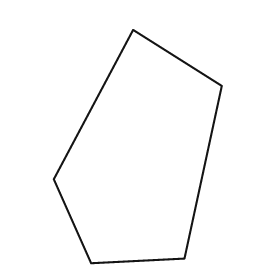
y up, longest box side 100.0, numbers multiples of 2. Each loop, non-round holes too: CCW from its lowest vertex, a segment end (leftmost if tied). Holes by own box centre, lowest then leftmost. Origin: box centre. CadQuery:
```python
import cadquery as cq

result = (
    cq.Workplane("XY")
    .moveTo(-20.0, -50.0)
    .lineTo(20.0, -48.0)
    .lineTo(36.0, 26.0)
    .lineTo(-2.0, 50.0)
    .lineTo(-36.0, -14.0)
    .close()
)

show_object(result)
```